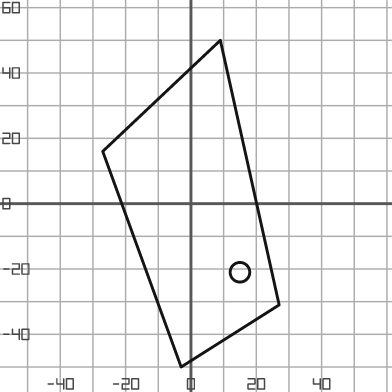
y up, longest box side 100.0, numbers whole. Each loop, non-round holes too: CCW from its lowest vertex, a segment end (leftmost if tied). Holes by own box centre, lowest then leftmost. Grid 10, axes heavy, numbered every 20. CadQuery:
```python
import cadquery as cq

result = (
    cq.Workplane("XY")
    .moveTo(-3.0, -50.0)
    .lineTo(27.0, -31.0)
    .lineTo(9.0, 50.0)
    .lineTo(-27.0, 16.0)
    .close()
    .moveTo(15.0, -21.0)
    .circle(3.0)
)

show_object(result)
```